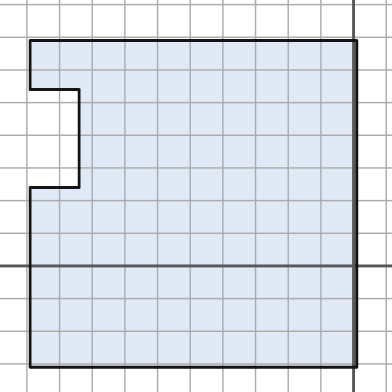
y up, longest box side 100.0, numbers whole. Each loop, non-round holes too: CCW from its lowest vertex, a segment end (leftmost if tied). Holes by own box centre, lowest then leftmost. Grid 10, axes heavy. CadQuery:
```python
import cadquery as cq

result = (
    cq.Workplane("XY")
    .moveTo(-99.0, -31.0)
    .lineTo(1.0, -31.0)
    .lineTo(1.0, 69.0)
    .lineTo(-99.0, 69.0)
    .lineTo(-99.0, 54.0)
    .lineTo(-84.0, 54.0)
    .lineTo(-84.0, 24.0)
    .lineTo(-99.0, 24.0)
    .close()
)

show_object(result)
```